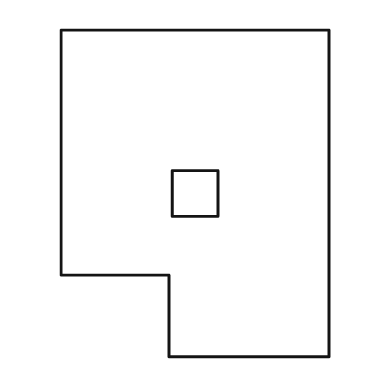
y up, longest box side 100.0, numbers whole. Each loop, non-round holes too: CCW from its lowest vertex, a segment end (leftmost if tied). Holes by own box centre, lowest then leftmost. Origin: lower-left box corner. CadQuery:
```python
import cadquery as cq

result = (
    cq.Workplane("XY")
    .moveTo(33.0, 0.0)
    .lineTo(82.0, 0.0)
    .lineTo(82.0, 100.0)
    .lineTo(0.0, 100.0)
    .lineTo(0.0, 25.0)
    .lineTo(33.0, 25.0)
    .close()
    .moveTo(34.0, 43.0)
    .lineTo(48.0, 43.0)
    .lineTo(48.0, 57.0)
    .lineTo(34.0, 57.0)
    .close()
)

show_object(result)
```